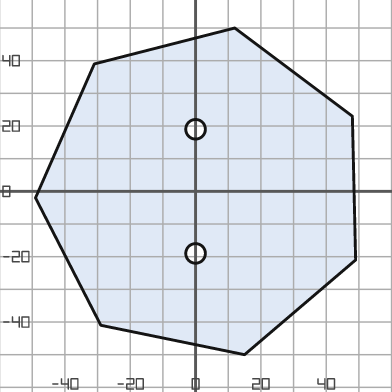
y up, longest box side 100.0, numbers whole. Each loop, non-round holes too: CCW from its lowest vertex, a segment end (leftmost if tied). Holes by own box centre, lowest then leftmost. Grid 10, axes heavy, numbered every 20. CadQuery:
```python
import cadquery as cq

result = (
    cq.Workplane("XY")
    .moveTo(15.0, -50.0)
    .lineTo(49.0, -21.0)
    .lineTo(48.0, 23.0)
    .lineTo(12.0, 50.0)
    .lineTo(-31.0, 39.0)
    .lineTo(-49.0, -2.0)
    .lineTo(-29.0, -41.0)
    .close()
    .moveTo(0.0, -19.0)
    .circle(3.0)
    .moveTo(0.0, 19.0)
    .circle(3.0)
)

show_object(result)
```